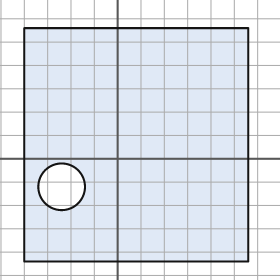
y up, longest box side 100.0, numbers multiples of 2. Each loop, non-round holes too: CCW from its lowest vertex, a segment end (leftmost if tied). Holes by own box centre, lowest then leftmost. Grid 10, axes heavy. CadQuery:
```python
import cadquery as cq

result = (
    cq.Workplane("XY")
    .moveTo(-40.0, -44.0)
    .lineTo(56.0, -44.0)
    .lineTo(56.0, 56.0)
    .lineTo(-40.0, 56.0)
    .close()
    .moveTo(-24.0, -12.0)
    .circle(10.0)
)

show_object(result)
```